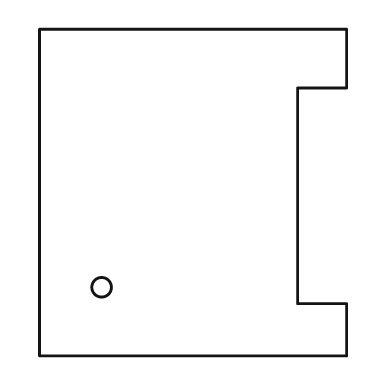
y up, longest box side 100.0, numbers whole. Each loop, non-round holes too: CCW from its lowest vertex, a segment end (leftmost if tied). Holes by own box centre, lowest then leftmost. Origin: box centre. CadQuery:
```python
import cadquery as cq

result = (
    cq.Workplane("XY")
    .moveTo(-47.0, -50.0)
    .lineTo(47.0, -50.0)
    .lineTo(47.0, -34.0)
    .lineTo(32.0, -34.0)
    .lineTo(32.0, 32.0)
    .lineTo(47.0, 32.0)
    .lineTo(47.0, 50.0)
    .lineTo(-47.0, 50.0)
    .close()
    .moveTo(-28.0, -29.0)
    .circle(3.0)
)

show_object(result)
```